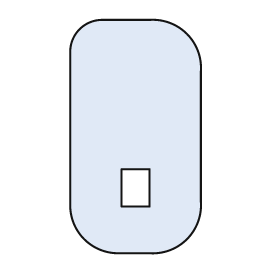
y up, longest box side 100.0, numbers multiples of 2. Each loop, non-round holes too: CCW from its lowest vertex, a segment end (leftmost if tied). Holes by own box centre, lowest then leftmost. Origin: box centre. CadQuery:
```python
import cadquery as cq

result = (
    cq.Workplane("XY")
    .moveTo(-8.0, -50.0)
    .lineTo(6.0, -50.0)
    .threePointArc((22.0, -44.0), (28.0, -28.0))
    .lineTo(28.0, 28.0)
    .threePointArc((22.0, 44.0), (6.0, 50.0))
    .lineTo(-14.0, 50.0)
    .threePointArc((-24.0, 46.0), (-28.0, 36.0))
    .lineTo(-28.0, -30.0)
    .threePointArc((-22.0, -44.0), (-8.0, -50.0))
    .close()
    .moveTo(-6.0, -30.0)
    .lineTo(6.0, -30.0)
    .lineTo(6.0, -14.0)
    .lineTo(-6.0, -14.0)
    .close()
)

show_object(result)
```